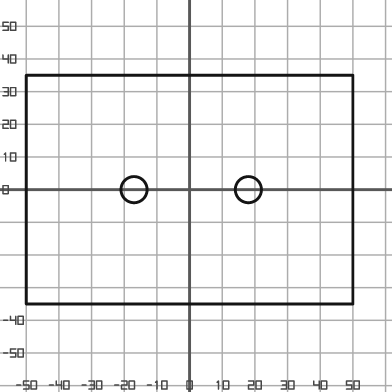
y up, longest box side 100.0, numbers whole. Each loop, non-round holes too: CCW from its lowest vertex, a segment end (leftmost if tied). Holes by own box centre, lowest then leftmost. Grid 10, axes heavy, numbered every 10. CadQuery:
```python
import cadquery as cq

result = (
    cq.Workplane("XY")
    .moveTo(-50.0, -35.0)
    .lineTo(50.0, -35.0)
    .lineTo(50.0, 35.0)
    .lineTo(-50.0, 35.0)
    .close()
    .moveTo(-17.0, 0.0)
    .circle(4.0)
    .moveTo(18.0, 0.0)
    .circle(4.0)
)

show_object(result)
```